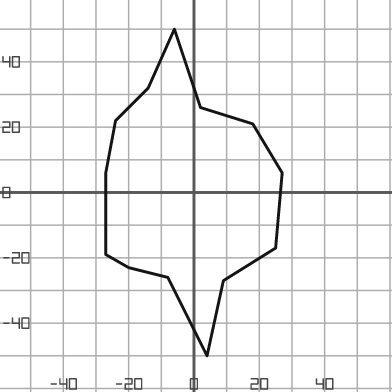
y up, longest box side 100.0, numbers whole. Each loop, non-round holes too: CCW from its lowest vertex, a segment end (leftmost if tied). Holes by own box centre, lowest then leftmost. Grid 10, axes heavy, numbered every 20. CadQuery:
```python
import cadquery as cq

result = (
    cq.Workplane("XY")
    .moveTo(4.0, -50.0)
    .lineTo(9.0, -27.0)
    .lineTo(25.0, -17.0)
    .lineTo(27.0, 6.0)
    .lineTo(18.0, 21.0)
    .lineTo(2.0, 26.0)
    .lineTo(-6.0, 50.0)
    .lineTo(-14.0, 32.0)
    .lineTo(-24.0, 22.0)
    .lineTo(-27.0, 6.0)
    .lineTo(-27.0, -19.0)
    .lineTo(-20.0, -23.0)
    .lineTo(-8.0, -26.0)
    .close()
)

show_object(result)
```